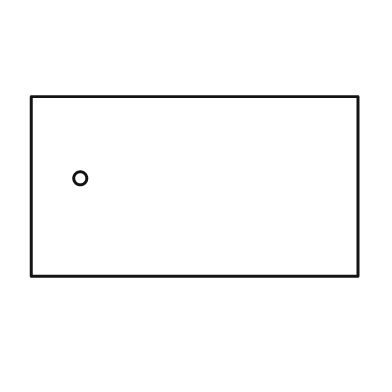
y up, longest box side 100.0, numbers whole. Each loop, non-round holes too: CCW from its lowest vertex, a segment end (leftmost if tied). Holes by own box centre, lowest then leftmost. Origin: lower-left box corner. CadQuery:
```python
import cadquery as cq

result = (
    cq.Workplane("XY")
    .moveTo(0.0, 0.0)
    .lineTo(100.0, 0.0)
    .lineTo(100.0, 55.0)
    .lineTo(0.0, 55.0)
    .close()
    .moveTo(15.0, 30.0)
    .circle(2.0)
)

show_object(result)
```